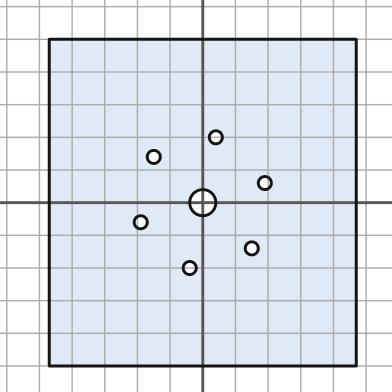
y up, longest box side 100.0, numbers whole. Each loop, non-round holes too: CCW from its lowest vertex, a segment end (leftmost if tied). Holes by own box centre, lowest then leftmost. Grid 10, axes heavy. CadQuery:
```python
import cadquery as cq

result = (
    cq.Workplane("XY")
    .moveTo(-47.0, -50.0)
    .lineTo(47.0, -50.0)
    .lineTo(47.0, 50.0)
    .lineTo(-47.0, 50.0)
    .close()
    .moveTo(-4.0, -20.0)
    .circle(2.0)
    .moveTo(15.0, -14.0)
    .circle(2.0)
    .moveTo(-19.0, -6.0)
    .circle(2.0)
    .moveTo(0.0, 0.0)
    .circle(4.0)
    .moveTo(19.0, 6.0)
    .circle(2.0)
    .moveTo(-15.0, 14.0)
    .circle(2.0)
    .moveTo(4.0, 20.0)
    .circle(2.0)
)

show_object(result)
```